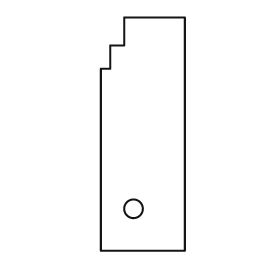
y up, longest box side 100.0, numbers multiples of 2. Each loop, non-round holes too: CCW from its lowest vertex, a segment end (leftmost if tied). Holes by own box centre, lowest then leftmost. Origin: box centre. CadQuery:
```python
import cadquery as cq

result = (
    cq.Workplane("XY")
    .moveTo(-18.0, -50.0)
    .lineTo(18.0, -50.0)
    .lineTo(18.0, 50.0)
    .lineTo(-8.0, 50.0)
    .lineTo(-8.0, 38.0)
    .lineTo(-14.0, 38.0)
    .lineTo(-14.0, 28.0)
    .lineTo(-18.0, 28.0)
    .close()
    .moveTo(-4.0, -32.0)
    .circle(4.0)
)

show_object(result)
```